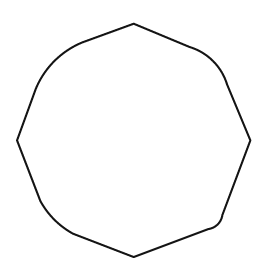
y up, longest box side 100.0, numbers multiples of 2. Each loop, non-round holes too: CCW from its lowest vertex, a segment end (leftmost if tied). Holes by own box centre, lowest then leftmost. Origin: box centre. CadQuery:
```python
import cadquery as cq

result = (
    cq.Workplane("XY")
    .moveTo(0.0, -50.0)
    .lineTo(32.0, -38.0)
    .threePointArc((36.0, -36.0), (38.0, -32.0))
    .lineTo(50.0, 0.0)
    .lineTo(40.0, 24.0)
    .threePointArc((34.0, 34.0), (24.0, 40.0))
    .lineTo(0.0, 50.0)
    .lineTo(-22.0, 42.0)
    .threePointArc((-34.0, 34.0), (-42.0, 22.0))
    .lineTo(-50.0, 0.0)
    .lineTo(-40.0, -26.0)
    .threePointArc((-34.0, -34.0), (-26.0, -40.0))
    .close()
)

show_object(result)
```